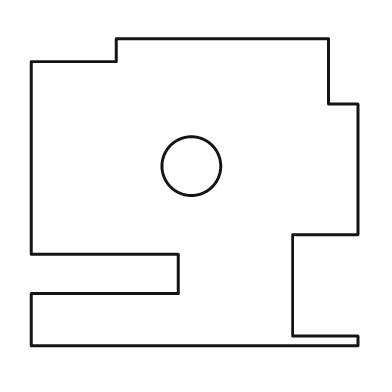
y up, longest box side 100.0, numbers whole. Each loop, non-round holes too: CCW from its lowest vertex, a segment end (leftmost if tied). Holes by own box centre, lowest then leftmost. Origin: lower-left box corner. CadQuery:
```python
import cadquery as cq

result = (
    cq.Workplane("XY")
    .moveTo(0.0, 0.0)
    .lineTo(100.0, 0.0)
    .lineTo(100.0, 3.0)
    .lineTo(80.0, 3.0)
    .lineTo(80.0, 34.0)
    .lineTo(100.0, 34.0)
    .lineTo(100.0, 74.0)
    .lineTo(91.0, 74.0)
    .lineTo(91.0, 94.0)
    .lineTo(26.0, 94.0)
    .lineTo(26.0, 87.0)
    .lineTo(0.0, 87.0)
    .lineTo(0.0, 28.0)
    .lineTo(45.0, 28.0)
    .lineTo(45.0, 16.0)
    .lineTo(0.0, 16.0)
    .close()
    .moveTo(49.0, 55.0)
    .circle(9.0)
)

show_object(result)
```